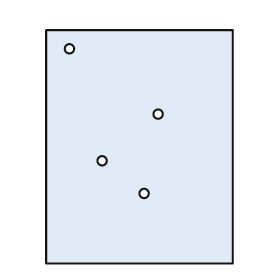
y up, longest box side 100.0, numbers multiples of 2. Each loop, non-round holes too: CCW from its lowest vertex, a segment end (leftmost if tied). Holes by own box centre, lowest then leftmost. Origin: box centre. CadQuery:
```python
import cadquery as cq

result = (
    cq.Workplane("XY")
    .moveTo(-40.0, -50.0)
    .lineTo(40.0, -50.0)
    .lineTo(40.0, 50.0)
    .lineTo(-40.0, 50.0)
    .close()
    .moveTo(2.0, -20.0)
    .circle(2.0)
    .moveTo(-16.0, -6.0)
    .circle(2.0)
    .moveTo(8.0, 14.0)
    .circle(2.0)
    .moveTo(-30.0, 42.0)
    .circle(2.0)
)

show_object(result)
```